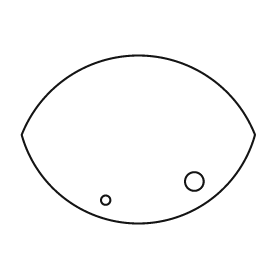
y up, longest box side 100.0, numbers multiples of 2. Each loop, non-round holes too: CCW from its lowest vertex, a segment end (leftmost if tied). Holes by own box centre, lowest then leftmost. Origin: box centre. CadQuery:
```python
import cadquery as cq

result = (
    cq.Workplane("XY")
    .moveTo(-50.0, 2.0)
    .threePointArc((0.0, -36.0), (50.0, 2.0))
    .threePointArc((0.0, 36.0), (-50.0, 2.0))
    .close()
    .moveTo(-14.0, -26.0)
    .circle(2.0)
    .moveTo(24.0, -18.0)
    .circle(4.0)
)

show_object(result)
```